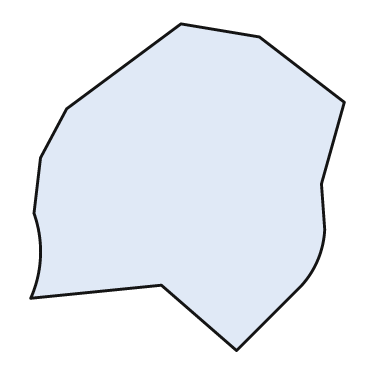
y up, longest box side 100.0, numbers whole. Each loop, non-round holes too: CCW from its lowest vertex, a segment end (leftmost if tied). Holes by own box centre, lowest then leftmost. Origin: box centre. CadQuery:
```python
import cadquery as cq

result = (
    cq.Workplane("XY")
    .moveTo(15.0, -50.0)
    .lineTo(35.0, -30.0)
    .threePointArc((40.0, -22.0), (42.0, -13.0))
    .lineTo(41.0, 1.0)
    .lineTo(48.0, 26.0)
    .lineTo(22.0, 46.0)
    .lineTo(-2.0, 50.0)
    .lineTo(-37.0, 24.0)
    .lineTo(-45.0, 9.0)
    .lineTo(-47.0, -8.0)
    .threePointArc((-45.0, -21.0), (-48.0, -34.0))
    .lineTo(-8.0, -30.0)
    .close()
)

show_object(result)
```